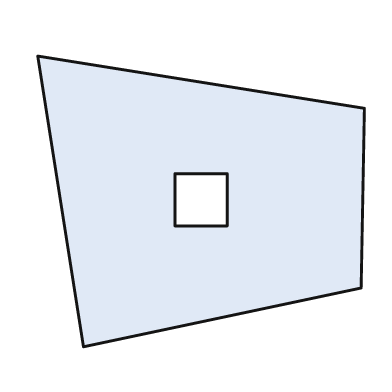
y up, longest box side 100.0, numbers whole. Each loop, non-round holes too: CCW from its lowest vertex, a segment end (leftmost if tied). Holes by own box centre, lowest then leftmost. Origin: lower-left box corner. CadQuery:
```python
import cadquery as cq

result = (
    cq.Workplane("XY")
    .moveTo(14.0, 0.0)
    .lineTo(99.0, 18.0)
    .lineTo(100.0, 73.0)
    .lineTo(0.0, 89.0)
    .close()
    .moveTo(42.0, 37.0)
    .lineTo(58.0, 37.0)
    .lineTo(58.0, 53.0)
    .lineTo(42.0, 53.0)
    .close()
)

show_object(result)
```